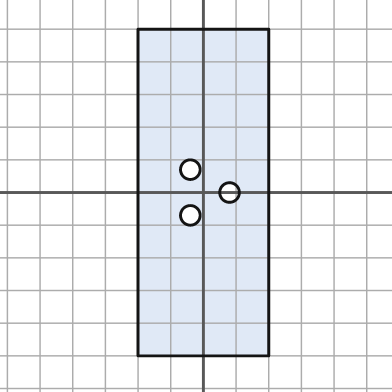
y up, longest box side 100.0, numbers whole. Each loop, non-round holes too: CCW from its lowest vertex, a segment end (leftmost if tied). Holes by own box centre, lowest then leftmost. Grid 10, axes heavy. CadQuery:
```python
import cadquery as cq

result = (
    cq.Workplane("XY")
    .moveTo(-20.0, -50.0)
    .lineTo(20.0, -50.0)
    .lineTo(20.0, 50.0)
    .lineTo(-20.0, 50.0)
    .close()
    .moveTo(-4.0, -7.0)
    .circle(3.0)
    .moveTo(8.0, 0.0)
    .circle(3.0)
    .moveTo(-4.0, 7.0)
    .circle(3.0)
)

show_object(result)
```